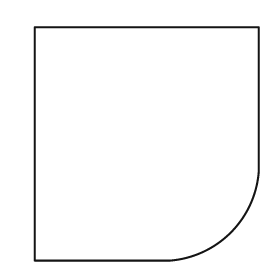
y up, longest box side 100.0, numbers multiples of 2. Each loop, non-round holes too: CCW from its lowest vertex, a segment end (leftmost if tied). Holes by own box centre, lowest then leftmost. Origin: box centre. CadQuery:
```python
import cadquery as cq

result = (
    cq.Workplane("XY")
    .moveTo(-48.0, -50.0)
    .lineTo(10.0, -50.0)
    .threePointArc((36.0, -38.0), (48.0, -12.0))
    .lineTo(48.0, 50.0)
    .lineTo(-48.0, 50.0)
    .close()
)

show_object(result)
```